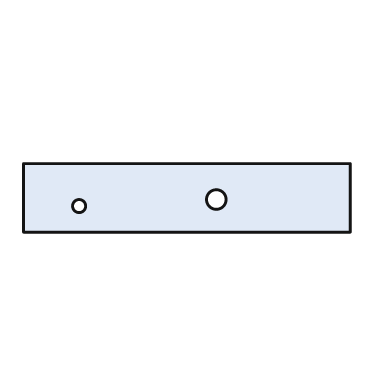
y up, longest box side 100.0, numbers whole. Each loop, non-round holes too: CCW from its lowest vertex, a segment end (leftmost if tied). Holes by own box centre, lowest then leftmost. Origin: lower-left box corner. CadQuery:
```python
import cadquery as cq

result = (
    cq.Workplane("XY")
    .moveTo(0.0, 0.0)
    .lineTo(100.0, 0.0)
    .lineTo(100.0, 21.0)
    .lineTo(0.0, 21.0)
    .close()
    .moveTo(17.0, 8.0)
    .circle(2.0)
    .moveTo(59.0, 10.0)
    .circle(3.0)
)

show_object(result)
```